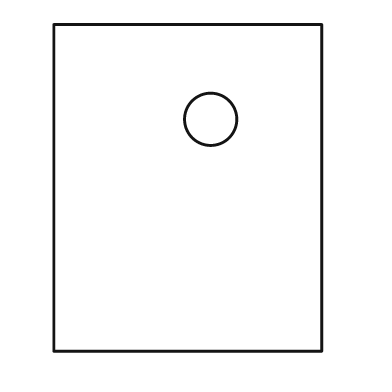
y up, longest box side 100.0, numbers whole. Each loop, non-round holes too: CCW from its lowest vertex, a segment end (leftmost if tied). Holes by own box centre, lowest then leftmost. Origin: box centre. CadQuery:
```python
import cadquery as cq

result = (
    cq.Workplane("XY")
    .moveTo(-41.0, -50.0)
    .lineTo(41.0, -50.0)
    .lineTo(41.0, 50.0)
    .lineTo(-41.0, 50.0)
    .close()
    .moveTo(7.0, 21.0)
    .circle(8.0)
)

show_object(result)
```